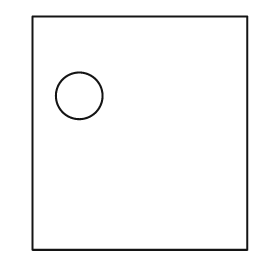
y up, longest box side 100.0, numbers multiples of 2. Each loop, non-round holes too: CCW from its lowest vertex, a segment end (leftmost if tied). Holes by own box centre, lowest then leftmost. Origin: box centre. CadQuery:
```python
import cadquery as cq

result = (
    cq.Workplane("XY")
    .moveTo(-46.0, -50.0)
    .lineTo(46.0, -50.0)
    .lineTo(46.0, 50.0)
    .lineTo(-46.0, 50.0)
    .close()
    .moveTo(-26.0, 16.0)
    .circle(10.0)
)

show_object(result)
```